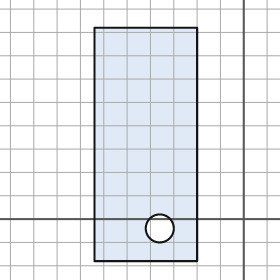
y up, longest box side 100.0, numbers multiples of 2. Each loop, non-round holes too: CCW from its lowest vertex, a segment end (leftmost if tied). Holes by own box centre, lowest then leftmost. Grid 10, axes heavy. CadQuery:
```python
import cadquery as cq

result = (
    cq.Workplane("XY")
    .moveTo(-64.0, -18.0)
    .lineTo(-20.0, -18.0)
    .lineTo(-20.0, 82.0)
    .lineTo(-64.0, 82.0)
    .close()
    .moveTo(-36.0, -4.0)
    .circle(6.0)
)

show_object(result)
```